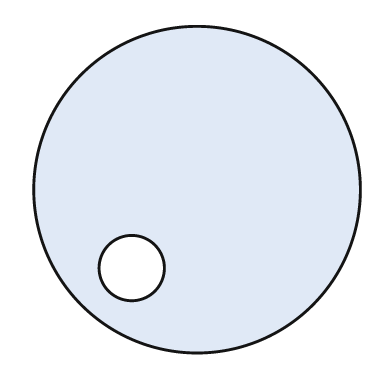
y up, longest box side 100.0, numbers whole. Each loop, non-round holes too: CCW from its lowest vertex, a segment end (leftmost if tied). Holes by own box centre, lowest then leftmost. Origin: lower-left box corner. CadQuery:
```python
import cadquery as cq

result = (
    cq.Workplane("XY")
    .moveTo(50.0, 50.0)
    .circle(50.0)
    .moveTo(30.0, 26.0)
    .circle(10.0)
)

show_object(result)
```